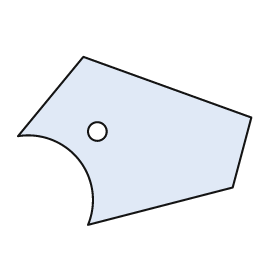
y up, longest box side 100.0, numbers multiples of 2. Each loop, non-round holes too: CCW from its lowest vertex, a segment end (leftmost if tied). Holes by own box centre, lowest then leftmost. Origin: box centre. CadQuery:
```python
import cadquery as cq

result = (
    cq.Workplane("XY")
    .moveTo(-20.0, -36.0)
    .lineTo(42.0, -20.0)
    .lineTo(50.0, 10.0)
    .lineTo(-22.0, 36.0)
    .lineTo(-50.0, 2.0)
    .threePointArc((-24.0, -8.0), (-20.0, -36.0))
    .close()
    .moveTo(-16.0, 4.0)
    .circle(4.0)
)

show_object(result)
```